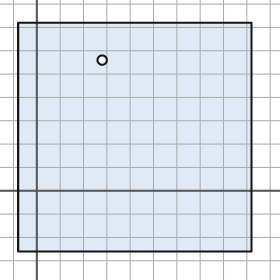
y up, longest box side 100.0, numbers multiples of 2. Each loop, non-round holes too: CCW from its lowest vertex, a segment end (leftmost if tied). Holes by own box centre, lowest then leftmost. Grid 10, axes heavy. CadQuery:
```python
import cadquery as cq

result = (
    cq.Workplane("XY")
    .moveTo(-8.0, -26.0)
    .lineTo(92.0, -26.0)
    .lineTo(92.0, 72.0)
    .lineTo(-8.0, 72.0)
    .close()
    .moveTo(28.0, 56.0)
    .circle(2.0)
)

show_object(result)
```